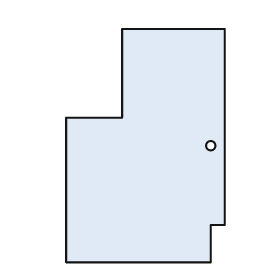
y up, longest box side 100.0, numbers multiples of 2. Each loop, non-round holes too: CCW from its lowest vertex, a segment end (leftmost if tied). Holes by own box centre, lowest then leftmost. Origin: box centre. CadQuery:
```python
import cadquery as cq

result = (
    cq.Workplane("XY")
    .moveTo(-34.0, -50.0)
    .lineTo(28.0, -50.0)
    .lineTo(28.0, -34.0)
    .lineTo(34.0, -34.0)
    .lineTo(34.0, 50.0)
    .lineTo(-10.0, 50.0)
    .lineTo(-10.0, 12.0)
    .lineTo(-34.0, 12.0)
    .close()
    .moveTo(28.0, 0.0)
    .circle(2.0)
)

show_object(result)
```